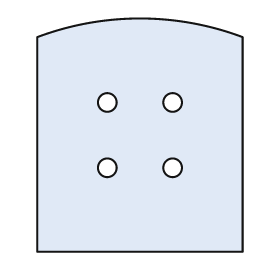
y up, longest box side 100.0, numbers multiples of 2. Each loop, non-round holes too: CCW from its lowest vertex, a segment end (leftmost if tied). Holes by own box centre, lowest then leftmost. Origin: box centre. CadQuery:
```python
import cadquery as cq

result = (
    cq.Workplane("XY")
    .moveTo(-44.0, -50.0)
    .lineTo(44.0, -50.0)
    .lineTo(44.0, 42.0)
    .threePointArc((0.0, 50.0), (-44.0, 42.0))
    .close()
    .moveTo(-14.0, -14.0)
    .circle(4.0)
    .moveTo(14.0, -14.0)
    .circle(4.0)
    .moveTo(-14.0, 14.0)
    .circle(4.0)
    .moveTo(14.0, 14.0)
    .circle(4.0)
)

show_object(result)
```